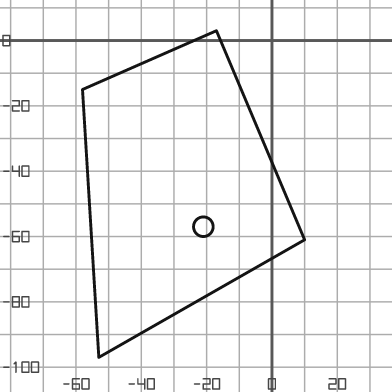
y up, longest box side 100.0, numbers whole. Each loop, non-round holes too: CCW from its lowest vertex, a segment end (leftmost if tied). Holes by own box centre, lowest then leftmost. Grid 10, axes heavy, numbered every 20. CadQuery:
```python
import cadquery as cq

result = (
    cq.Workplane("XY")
    .moveTo(-53.0, -97.0)
    .lineTo(10.0, -61.0)
    .lineTo(-17.0, 3.0)
    .lineTo(-58.0, -15.0)
    .close()
    .moveTo(-21.0, -57.0)
    .circle(3.0)
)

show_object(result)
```